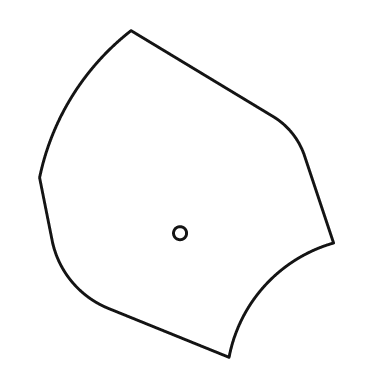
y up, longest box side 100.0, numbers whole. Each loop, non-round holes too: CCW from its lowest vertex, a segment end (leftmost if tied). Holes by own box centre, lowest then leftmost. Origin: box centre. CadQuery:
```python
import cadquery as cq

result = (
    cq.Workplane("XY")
    .moveTo(13.0, -50.0)
    .threePointArc((24.0, -28.0), (45.0, -15.0))
    .lineTo(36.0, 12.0)
    .threePointArc((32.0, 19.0), (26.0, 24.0))
    .lineTo(-17.0, 50.0)
    .threePointArc((-35.0, 30.0), (-45.0, 5.0))
    .lineTo(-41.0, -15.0)
    .threePointArc((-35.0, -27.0), (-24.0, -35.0))
    .close()
    .moveTo(-2.0, -12.0)
    .circle(2.0)
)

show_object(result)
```